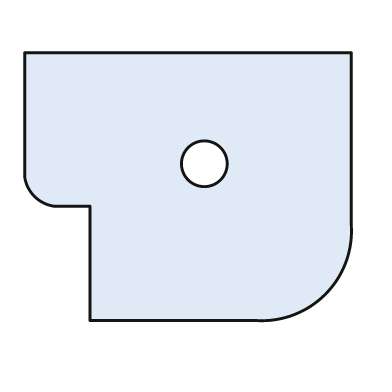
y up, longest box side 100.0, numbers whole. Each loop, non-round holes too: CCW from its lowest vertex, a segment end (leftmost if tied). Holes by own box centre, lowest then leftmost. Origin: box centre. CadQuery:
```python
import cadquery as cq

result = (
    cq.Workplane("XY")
    .moveTo(-30.0, -41.0)
    .lineTo(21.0, -41.0)
    .threePointArc((42.0, -33.0), (50.0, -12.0))
    .lineTo(50.0, 41.0)
    .lineTo(-50.0, 41.0)
    .lineTo(-50.0, 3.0)
    .threePointArc((-47.0, -3.0), (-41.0, -6.0))
    .lineTo(-30.0, -6.0)
    .close()
    .moveTo(5.0, 7.0)
    .circle(7.0)
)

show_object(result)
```